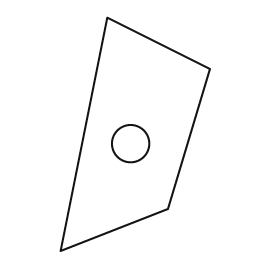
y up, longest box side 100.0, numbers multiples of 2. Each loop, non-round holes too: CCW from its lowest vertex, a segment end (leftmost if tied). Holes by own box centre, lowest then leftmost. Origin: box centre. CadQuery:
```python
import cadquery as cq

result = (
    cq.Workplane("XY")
    .moveTo(-32.0, -50.0)
    .lineTo(14.0, -32.0)
    .lineTo(32.0, 28.0)
    .lineTo(-12.0, 50.0)
    .close()
    .moveTo(-2.0, -4.0)
    .circle(8.0)
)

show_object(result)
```